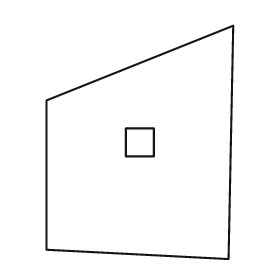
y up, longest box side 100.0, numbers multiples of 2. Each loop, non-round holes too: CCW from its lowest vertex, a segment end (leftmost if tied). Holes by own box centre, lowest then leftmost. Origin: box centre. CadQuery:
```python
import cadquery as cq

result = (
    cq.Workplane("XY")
    .moveTo(38.0, -50.0)
    .lineTo(40.0, 50.0)
    .lineTo(-40.0, 18.0)
    .lineTo(-40.0, -46.0)
    .close()
    .moveTo(-6.0, -6.0)
    .lineTo(6.0, -6.0)
    .lineTo(6.0, 6.0)
    .lineTo(-6.0, 6.0)
    .close()
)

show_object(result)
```